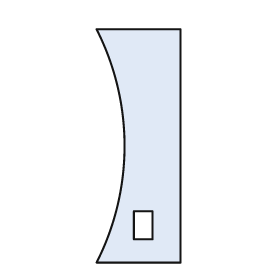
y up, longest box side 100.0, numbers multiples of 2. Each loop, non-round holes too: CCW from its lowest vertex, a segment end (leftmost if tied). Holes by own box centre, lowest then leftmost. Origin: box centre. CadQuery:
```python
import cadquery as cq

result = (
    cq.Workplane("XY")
    .moveTo(-18.0, -50.0)
    .lineTo(18.0, -50.0)
    .lineTo(18.0, 50.0)
    .lineTo(-18.0, 50.0)
    .threePointArc((-6.0, 0.0), (-18.0, -50.0))
    .close()
    .moveTo(-2.0, -40.0)
    .lineTo(6.0, -40.0)
    .lineTo(6.0, -28.0)
    .lineTo(-2.0, -28.0)
    .close()
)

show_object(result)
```